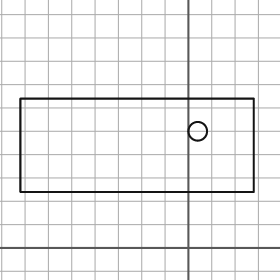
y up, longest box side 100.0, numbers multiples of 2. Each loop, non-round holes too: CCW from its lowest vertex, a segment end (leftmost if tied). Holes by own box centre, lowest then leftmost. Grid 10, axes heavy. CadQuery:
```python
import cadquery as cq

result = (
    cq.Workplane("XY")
    .moveTo(-72.0, 24.0)
    .lineTo(28.0, 24.0)
    .lineTo(28.0, 64.0)
    .lineTo(-72.0, 64.0)
    .close()
    .moveTo(4.0, 50.0)
    .circle(4.0)
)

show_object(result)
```